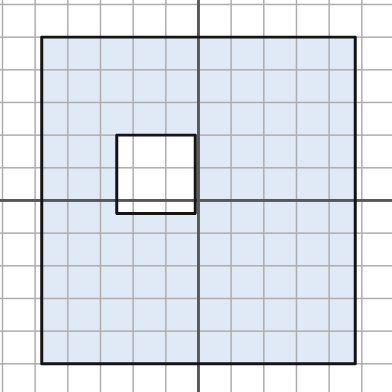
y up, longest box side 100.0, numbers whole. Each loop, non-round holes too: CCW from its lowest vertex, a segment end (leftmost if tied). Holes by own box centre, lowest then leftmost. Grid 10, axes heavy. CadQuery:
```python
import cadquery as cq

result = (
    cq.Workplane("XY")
    .moveTo(-48.0, -50.0)
    .lineTo(48.0, -50.0)
    .lineTo(48.0, 50.0)
    .lineTo(-48.0, 50.0)
    .close()
    .moveTo(-25.0, -4.0)
    .lineTo(-1.0, -4.0)
    .lineTo(-1.0, 20.0)
    .lineTo(-25.0, 20.0)
    .close()
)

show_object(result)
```